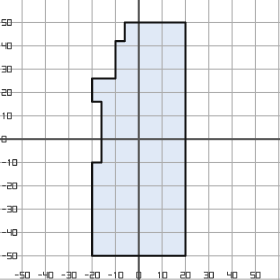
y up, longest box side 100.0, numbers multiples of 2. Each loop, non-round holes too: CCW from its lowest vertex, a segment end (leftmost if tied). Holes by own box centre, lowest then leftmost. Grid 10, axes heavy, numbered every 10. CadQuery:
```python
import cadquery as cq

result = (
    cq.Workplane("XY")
    .moveTo(-20.0, -50.0)
    .lineTo(20.0, -50.0)
    .lineTo(20.0, 50.0)
    .lineTo(-6.0, 50.0)
    .lineTo(-6.0, 42.0)
    .lineTo(-10.0, 42.0)
    .lineTo(-10.0, 26.0)
    .lineTo(-20.0, 26.0)
    .lineTo(-20.0, 16.0)
    .lineTo(-16.0, 16.0)
    .lineTo(-16.0, -10.0)
    .lineTo(-20.0, -10.0)
    .close()
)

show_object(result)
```